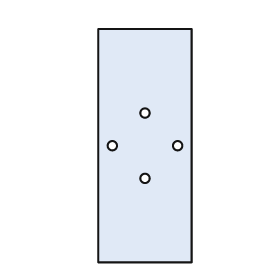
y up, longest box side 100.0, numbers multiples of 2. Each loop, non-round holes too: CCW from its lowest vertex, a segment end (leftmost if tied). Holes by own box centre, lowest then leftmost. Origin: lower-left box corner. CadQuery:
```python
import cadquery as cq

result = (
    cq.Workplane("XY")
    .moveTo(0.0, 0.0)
    .lineTo(40.0, 0.0)
    .lineTo(40.0, 100.0)
    .lineTo(0.0, 100.0)
    .close()
    .moveTo(20.0, 36.0)
    .circle(2.0)
    .moveTo(6.0, 50.0)
    .circle(2.0)
    .moveTo(34.0, 50.0)
    .circle(2.0)
    .moveTo(20.0, 64.0)
    .circle(2.0)
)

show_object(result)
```